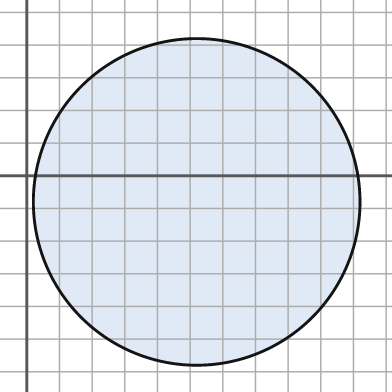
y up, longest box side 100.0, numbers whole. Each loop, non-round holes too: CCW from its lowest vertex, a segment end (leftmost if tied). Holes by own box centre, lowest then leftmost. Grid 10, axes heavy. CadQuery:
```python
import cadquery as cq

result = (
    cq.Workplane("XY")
    .moveTo(52.0, -8.0)
    .circle(50.0)
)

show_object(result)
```